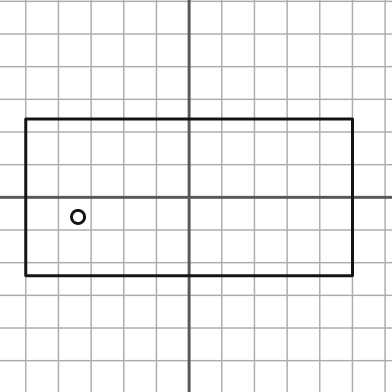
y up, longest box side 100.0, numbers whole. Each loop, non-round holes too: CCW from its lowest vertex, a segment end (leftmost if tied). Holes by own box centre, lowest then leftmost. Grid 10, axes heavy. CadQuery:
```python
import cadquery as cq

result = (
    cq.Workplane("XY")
    .moveTo(-50.0, -24.0)
    .lineTo(50.0, -24.0)
    .lineTo(50.0, 24.0)
    .lineTo(-50.0, 24.0)
    .close()
    .moveTo(-34.0, -6.0)
    .circle(2.0)
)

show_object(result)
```